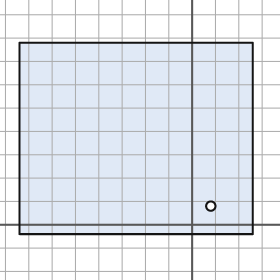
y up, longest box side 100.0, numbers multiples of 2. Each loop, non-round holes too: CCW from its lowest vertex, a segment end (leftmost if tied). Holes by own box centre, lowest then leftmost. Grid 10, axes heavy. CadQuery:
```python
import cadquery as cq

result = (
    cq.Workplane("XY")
    .moveTo(-74.0, -4.0)
    .lineTo(26.0, -4.0)
    .lineTo(26.0, 78.0)
    .lineTo(-74.0, 78.0)
    .close()
    .moveTo(8.0, 8.0)
    .circle(2.0)
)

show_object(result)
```